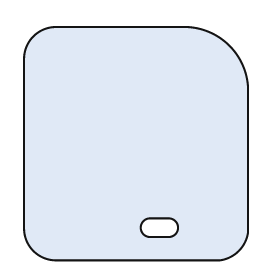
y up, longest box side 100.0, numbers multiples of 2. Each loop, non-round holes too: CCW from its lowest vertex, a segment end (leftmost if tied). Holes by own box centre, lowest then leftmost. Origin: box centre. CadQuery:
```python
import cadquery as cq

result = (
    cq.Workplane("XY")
    .moveTo(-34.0, -50.0)
    .lineTo(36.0, -50.0)
    .threePointArc((44.0, -46.0), (48.0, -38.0))
    .lineTo(48.0, 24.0)
    .threePointArc((40.0, 42.0), (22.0, 50.0))
    .lineTo(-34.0, 50.0)
    .threePointArc((-44.0, 46.0), (-48.0, 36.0))
    .lineTo(-48.0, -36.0)
    .threePointArc((-44.0, -46.0), (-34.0, -50.0))
    .close()
    .moveTo(6.0, -40.0)
    .lineTo(14.0, -40.0)
    .threePointArc((18.0, -36.0), (14.0, -32.0))
    .lineTo(6.0, -32.0)
    .threePointArc((2.0, -36.0), (6.0, -40.0))
    .close()
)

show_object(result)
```